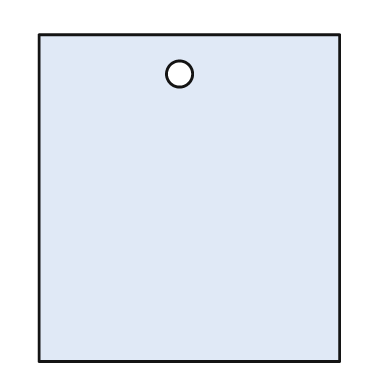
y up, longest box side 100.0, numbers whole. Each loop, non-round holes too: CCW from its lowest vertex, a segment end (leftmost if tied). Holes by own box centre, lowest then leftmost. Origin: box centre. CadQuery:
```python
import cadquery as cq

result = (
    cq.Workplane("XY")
    .moveTo(-46.0, -50.0)
    .lineTo(46.0, -50.0)
    .lineTo(46.0, 50.0)
    .lineTo(-46.0, 50.0)
    .close()
    .moveTo(-3.0, 38.0)
    .circle(4.0)
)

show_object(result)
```